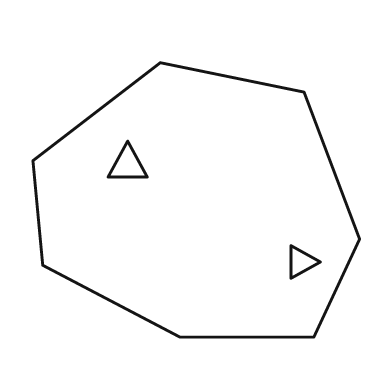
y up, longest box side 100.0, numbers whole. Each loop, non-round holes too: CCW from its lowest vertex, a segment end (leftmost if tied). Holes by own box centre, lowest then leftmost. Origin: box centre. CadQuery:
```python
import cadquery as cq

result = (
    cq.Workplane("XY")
    .moveTo(-5.0, -42.0)
    .lineTo(36.0, -42.0)
    .lineTo(50.0, -12.0)
    .lineTo(33.0, 33.0)
    .lineTo(-11.0, 42.0)
    .lineTo(-50.0, 12.0)
    .lineTo(-47.0, -20.0)
    .close()
    .moveTo(29.0, -24.0)
    .lineTo(38.0, -19.0)
    .lineTo(29.0, -14.0)
    .close()
    .moveTo(-27.0, 7.0)
    .lineTo(-15.0, 7.0)
    .lineTo(-21.0, 18.0)
    .close()
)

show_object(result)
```